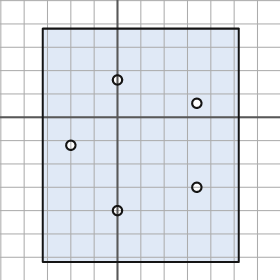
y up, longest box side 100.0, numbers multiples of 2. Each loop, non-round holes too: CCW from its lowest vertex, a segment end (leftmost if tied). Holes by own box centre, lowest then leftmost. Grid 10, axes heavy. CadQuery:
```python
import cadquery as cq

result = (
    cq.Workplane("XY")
    .moveTo(-32.0, -62.0)
    .lineTo(52.0, -62.0)
    .lineTo(52.0, 38.0)
    .lineTo(-32.0, 38.0)
    .close()
    .moveTo(0.0, -40.0)
    .circle(2.0)
    .moveTo(34.0, -30.0)
    .circle(2.0)
    .moveTo(-20.0, -12.0)
    .circle(2.0)
    .moveTo(34.0, 6.0)
    .circle(2.0)
    .moveTo(0.0, 16.0)
    .circle(2.0)
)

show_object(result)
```